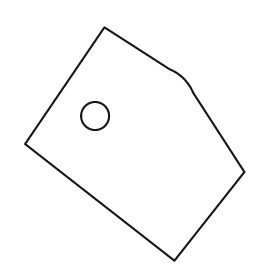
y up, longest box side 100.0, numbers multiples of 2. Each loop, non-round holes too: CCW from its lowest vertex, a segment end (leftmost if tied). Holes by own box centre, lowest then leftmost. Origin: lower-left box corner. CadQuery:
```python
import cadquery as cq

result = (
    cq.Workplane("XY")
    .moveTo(64.0, 0.0)
    .lineTo(94.0, 38.0)
    .lineTo(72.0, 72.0)
    .threePointArc((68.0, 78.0), (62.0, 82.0))
    .lineTo(34.0, 100.0)
    .lineTo(0.0, 50.0)
    .close()
    .moveTo(30.0, 62.0)
    .circle(6.0)
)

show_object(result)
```